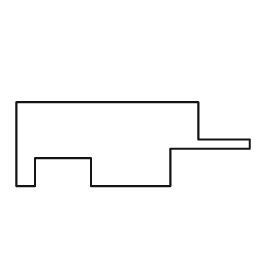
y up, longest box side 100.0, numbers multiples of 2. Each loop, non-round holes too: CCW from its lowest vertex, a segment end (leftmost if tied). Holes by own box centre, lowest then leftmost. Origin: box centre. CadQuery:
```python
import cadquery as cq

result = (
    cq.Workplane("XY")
    .moveTo(-50.0, -18.0)
    .lineTo(-42.0, -18.0)
    .lineTo(-42.0, -6.0)
    .lineTo(-18.0, -6.0)
    .lineTo(-18.0, -18.0)
    .lineTo(16.0, -18.0)
    .lineTo(16.0, -2.0)
    .lineTo(50.0, -2.0)
    .lineTo(50.0, 2.0)
    .lineTo(28.0, 2.0)
    .lineTo(28.0, 18.0)
    .lineTo(-50.0, 18.0)
    .close()
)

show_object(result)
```